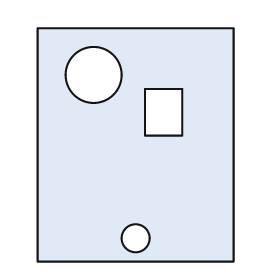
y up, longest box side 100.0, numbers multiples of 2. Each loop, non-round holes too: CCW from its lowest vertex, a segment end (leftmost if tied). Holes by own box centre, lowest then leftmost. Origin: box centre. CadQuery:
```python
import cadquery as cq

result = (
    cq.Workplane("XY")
    .moveTo(-42.0, -50.0)
    .lineTo(42.0, -50.0)
    .lineTo(42.0, 50.0)
    .lineTo(-42.0, 50.0)
    .close()
    .moveTo(0.0, -40.0)
    .circle(6.0)
    .moveTo(4.0, 4.0)
    .lineTo(20.0, 4.0)
    .lineTo(20.0, 24.0)
    .lineTo(4.0, 24.0)
    .close()
    .moveTo(-18.0, 30.0)
    .circle(12.0)
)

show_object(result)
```